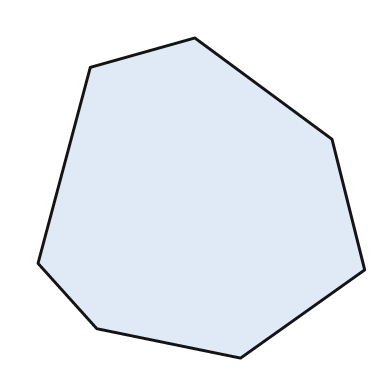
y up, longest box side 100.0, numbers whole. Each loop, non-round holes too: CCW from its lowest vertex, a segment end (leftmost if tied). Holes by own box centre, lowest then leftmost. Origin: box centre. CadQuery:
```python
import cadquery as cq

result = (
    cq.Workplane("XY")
    .moveTo(12.0, -49.0)
    .lineTo(50.0, -22.0)
    .lineTo(40.0, 18.0)
    .lineTo(-2.0, 49.0)
    .lineTo(-34.0, 40.0)
    .lineTo(-50.0, -20.0)
    .lineTo(-32.0, -40.0)
    .close()
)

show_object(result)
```